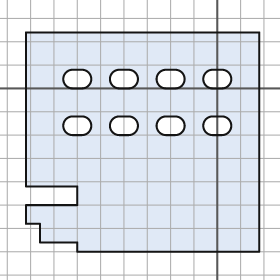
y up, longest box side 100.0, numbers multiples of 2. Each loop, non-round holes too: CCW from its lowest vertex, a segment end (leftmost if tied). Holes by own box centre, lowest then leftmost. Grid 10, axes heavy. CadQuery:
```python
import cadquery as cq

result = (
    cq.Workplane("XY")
    .moveTo(-60.0, -70.0)
    .lineTo(18.0, -70.0)
    .lineTo(18.0, 24.0)
    .lineTo(-82.0, 24.0)
    .lineTo(-82.0, -42.0)
    .lineTo(-60.0, -42.0)
    .lineTo(-60.0, -50.0)
    .lineTo(-82.0, -50.0)
    .lineTo(-82.0, -58.0)
    .lineTo(-76.0, -58.0)
    .lineTo(-76.0, -66.0)
    .lineTo(-60.0, -66.0)
    .close()
    .moveTo(-62.0, -20.0)
    .lineTo(-58.0, -20.0)
    .threePointArc((-54.0, -16.0), (-58.0, -12.0))
    .lineTo(-62.0, -12.0)
    .threePointArc((-66.0, -16.0), (-62.0, -20.0))
    .close()
    .moveTo(-42.0, -20.0)
    .lineTo(-38.0, -20.0)
    .threePointArc((-34.0, -16.0), (-38.0, -12.0))
    .lineTo(-42.0, -12.0)
    .threePointArc((-46.0, -16.0), (-42.0, -20.0))
    .close()
    .moveTo(-22.0, -20.0)
    .lineTo(-18.0, -20.0)
    .threePointArc((-14.0, -16.0), (-18.0, -12.0))
    .lineTo(-22.0, -12.0)
    .threePointArc((-26.0, -16.0), (-22.0, -20.0))
    .close()
    .moveTo(-2.0, -20.0)
    .lineTo(2.0, -20.0)
    .threePointArc((6.0, -16.0), (2.0, -12.0))
    .lineTo(-2.0, -12.0)
    .threePointArc((-6.0, -16.0), (-2.0, -20.0))
    .close()
    .moveTo(-62.0, 0.0)
    .lineTo(-58.0, 0.0)
    .threePointArc((-54.0, 4.0), (-58.0, 8.0))
    .lineTo(-62.0, 8.0)
    .threePointArc((-66.0, 4.0), (-62.0, 0.0))
    .close()
    .moveTo(-42.0, 0.0)
    .lineTo(-38.0, 0.0)
    .threePointArc((-34.0, 4.0), (-38.0, 8.0))
    .lineTo(-42.0, 8.0)
    .threePointArc((-46.0, 4.0), (-42.0, 0.0))
    .close()
    .moveTo(-22.0, 0.0)
    .lineTo(-18.0, 0.0)
    .threePointArc((-14.0, 4.0), (-18.0, 8.0))
    .lineTo(-22.0, 8.0)
    .threePointArc((-26.0, 4.0), (-22.0, 0.0))
    .close()
    .moveTo(-2.0, 0.0)
    .lineTo(2.0, 0.0)
    .threePointArc((6.0, 4.0), (2.0, 8.0))
    .lineTo(-2.0, 8.0)
    .threePointArc((-6.0, 4.0), (-2.0, 0.0))
    .close()
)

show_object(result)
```